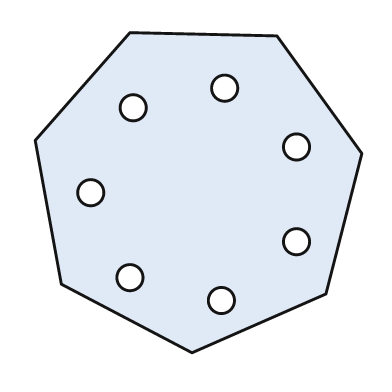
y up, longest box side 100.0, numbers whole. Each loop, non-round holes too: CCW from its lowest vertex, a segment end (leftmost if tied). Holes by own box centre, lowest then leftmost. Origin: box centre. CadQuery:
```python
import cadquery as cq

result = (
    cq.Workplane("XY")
    .moveTo(-2.0, -49.0)
    .lineTo(39.0, -31.0)
    .lineTo(50.0, 12.0)
    .lineTo(24.0, 48.0)
    .lineTo(-21.0, 49.0)
    .lineTo(-50.0, 16.0)
    .lineTo(-42.0, -28.0)
    .close()
    .moveTo(7.0, -33.0)
    .circle(4.0)
    .moveTo(-21.0, -26.0)
    .circle(4.0)
    .moveTo(30.0, -15.0)
    .circle(4.0)
    .moveTo(-33.0, 0.0)
    .circle(4.0)
    .moveTo(30.0, 14.0)
    .circle(4.0)
    .moveTo(-20.0, 26.0)
    .circle(4.0)
    .moveTo(8.0, 32.0)
    .circle(4.0)
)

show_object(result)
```